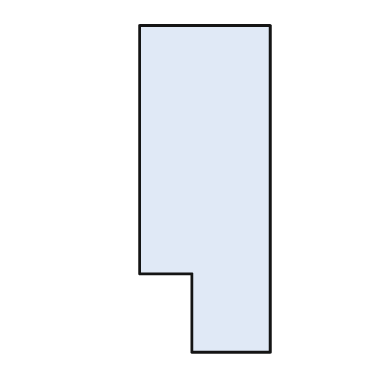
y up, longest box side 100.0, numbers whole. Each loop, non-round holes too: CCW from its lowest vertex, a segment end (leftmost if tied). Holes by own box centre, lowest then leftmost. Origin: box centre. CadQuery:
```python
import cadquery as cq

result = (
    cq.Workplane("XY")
    .moveTo(-4.0, -50.0)
    .lineTo(20.0, -50.0)
    .lineTo(20.0, 50.0)
    .lineTo(-20.0, 50.0)
    .lineTo(-20.0, -26.0)
    .lineTo(-4.0, -26.0)
    .close()
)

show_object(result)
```